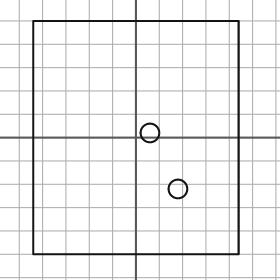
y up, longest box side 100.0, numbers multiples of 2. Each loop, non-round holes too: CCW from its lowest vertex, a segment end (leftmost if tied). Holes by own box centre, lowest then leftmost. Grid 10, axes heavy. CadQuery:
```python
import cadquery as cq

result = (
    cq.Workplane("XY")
    .moveTo(-44.0, -50.0)
    .lineTo(44.0, -50.0)
    .lineTo(44.0, 50.0)
    .lineTo(-44.0, 50.0)
    .close()
    .moveTo(18.0, -22.0)
    .circle(4.0)
    .moveTo(6.0, 2.0)
    .circle(4.0)
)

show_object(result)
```